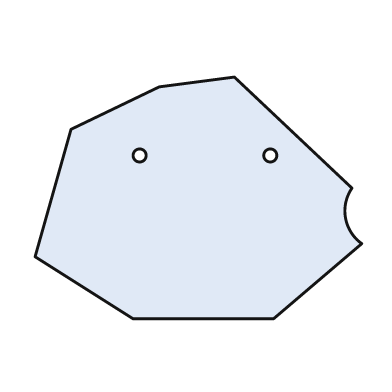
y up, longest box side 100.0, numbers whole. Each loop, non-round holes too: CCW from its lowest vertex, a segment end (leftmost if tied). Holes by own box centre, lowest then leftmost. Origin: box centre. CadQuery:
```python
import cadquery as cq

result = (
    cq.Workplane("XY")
    .moveTo(-20.0, -37.0)
    .lineTo(23.0, -37.0)
    .lineTo(50.0, -14.0)
    .threePointArc((45.0, -6.0), (47.0, 3.0))
    .lineTo(11.0, 37.0)
    .lineTo(-12.0, 34.0)
    .lineTo(-39.0, 21.0)
    .lineTo(-50.0, -18.0)
    .close()
    .moveTo(-18.0, 13.0)
    .circle(2.0)
    .moveTo(22.0, 13.0)
    .circle(2.0)
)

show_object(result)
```